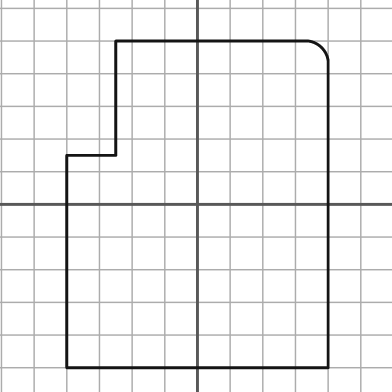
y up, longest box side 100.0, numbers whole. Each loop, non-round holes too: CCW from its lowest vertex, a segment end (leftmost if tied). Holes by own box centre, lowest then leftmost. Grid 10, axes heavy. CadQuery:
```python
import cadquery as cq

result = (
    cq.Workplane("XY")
    .moveTo(-40.0, -50.0)
    .lineTo(40.0, -50.0)
    .lineTo(40.0, 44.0)
    .threePointArc((38.0, 48.0), (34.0, 50.0))
    .lineTo(-25.0, 50.0)
    .lineTo(-25.0, 15.0)
    .lineTo(-40.0, 15.0)
    .close()
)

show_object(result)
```